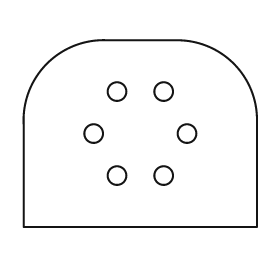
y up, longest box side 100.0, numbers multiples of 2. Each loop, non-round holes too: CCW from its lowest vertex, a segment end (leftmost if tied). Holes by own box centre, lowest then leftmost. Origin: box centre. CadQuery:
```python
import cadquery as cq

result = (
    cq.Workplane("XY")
    .moveTo(-50.0, -40.0)
    .lineTo(50.0, -40.0)
    .lineTo(50.0, 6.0)
    .threePointArc((40.0, 30.0), (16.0, 40.0))
    .lineTo(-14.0, 40.0)
    .threePointArc((-40.0, 30.0), (-50.0, 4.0))
    .close()
    .moveTo(-10.0, -18.0)
    .circle(4.0)
    .moveTo(10.0, -18.0)
    .circle(4.0)
    .moveTo(-20.0, 0.0)
    .circle(4.0)
    .moveTo(20.0, 0.0)
    .circle(4.0)
    .moveTo(-10.0, 18.0)
    .circle(4.0)
    .moveTo(10.0, 18.0)
    .circle(4.0)
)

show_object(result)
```